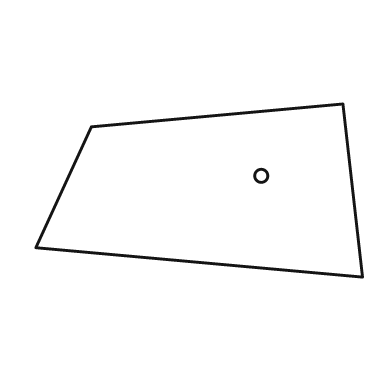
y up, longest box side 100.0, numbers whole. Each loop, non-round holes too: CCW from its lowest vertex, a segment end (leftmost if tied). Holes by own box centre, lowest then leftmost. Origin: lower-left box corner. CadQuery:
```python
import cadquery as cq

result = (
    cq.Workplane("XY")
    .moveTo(100.0, 0.0)
    .lineTo(94.0, 53.0)
    .lineTo(17.0, 46.0)
    .lineTo(0.0, 9.0)
    .close()
    .moveTo(69.0, 31.0)
    .circle(2.0)
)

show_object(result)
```